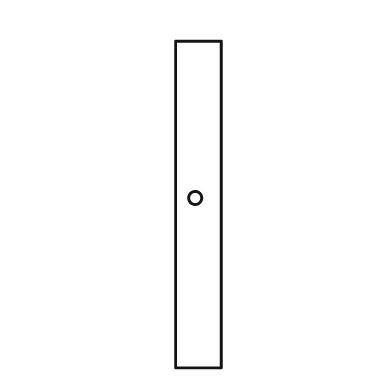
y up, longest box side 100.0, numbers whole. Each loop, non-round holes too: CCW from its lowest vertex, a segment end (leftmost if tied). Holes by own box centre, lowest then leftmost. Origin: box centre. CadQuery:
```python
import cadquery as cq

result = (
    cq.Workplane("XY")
    .moveTo(-7.0, -50.0)
    .lineTo(7.0, -50.0)
    .lineTo(7.0, 50.0)
    .lineTo(-7.0, 50.0)
    .close()
    .moveTo(-1.0, 2.0)
    .circle(2.0)
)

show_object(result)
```